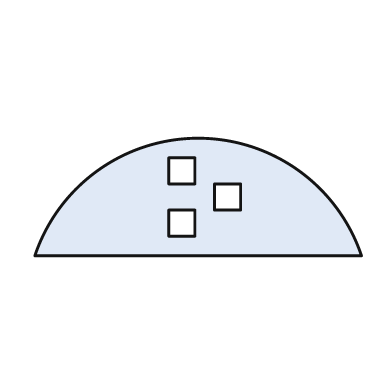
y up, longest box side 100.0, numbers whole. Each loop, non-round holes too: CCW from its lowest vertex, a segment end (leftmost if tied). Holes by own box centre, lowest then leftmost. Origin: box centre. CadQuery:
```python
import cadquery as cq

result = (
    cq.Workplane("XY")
    .moveTo(-50.0, -18.0)
    .lineTo(50.0, -18.0)
    .threePointArc((0.0, 18.0), (-50.0, -18.0))
    .close()
    .moveTo(-9.0, -12.0)
    .lineTo(-1.0, -12.0)
    .lineTo(-1.0, -4.0)
    .lineTo(-9.0, -4.0)
    .close()
    .moveTo(5.0, -4.0)
    .lineTo(13.0, -4.0)
    .lineTo(13.0, 4.0)
    .lineTo(5.0, 4.0)
    .close()
    .moveTo(-9.0, 4.0)
    .lineTo(-1.0, 4.0)
    .lineTo(-1.0, 12.0)
    .lineTo(-9.0, 12.0)
    .close()
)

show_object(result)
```